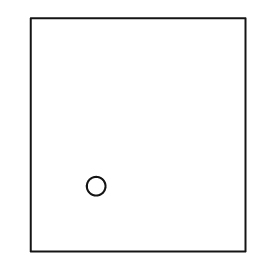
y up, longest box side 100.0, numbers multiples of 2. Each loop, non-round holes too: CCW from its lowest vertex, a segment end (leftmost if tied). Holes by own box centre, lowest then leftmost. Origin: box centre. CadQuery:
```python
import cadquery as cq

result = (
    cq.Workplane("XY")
    .moveTo(-46.0, -50.0)
    .lineTo(46.0, -50.0)
    .lineTo(46.0, 50.0)
    .lineTo(-46.0, 50.0)
    .close()
    .moveTo(-18.0, -22.0)
    .circle(4.0)
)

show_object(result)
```